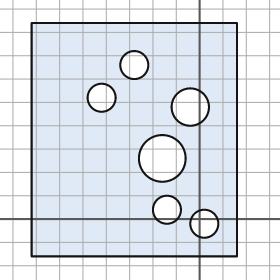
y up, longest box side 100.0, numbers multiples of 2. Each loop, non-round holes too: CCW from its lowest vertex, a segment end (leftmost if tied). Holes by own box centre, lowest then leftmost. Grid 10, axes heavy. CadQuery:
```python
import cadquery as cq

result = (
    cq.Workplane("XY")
    .moveTo(-72.0, -16.0)
    .lineTo(16.0, -16.0)
    .lineTo(16.0, 84.0)
    .lineTo(-72.0, 84.0)
    .close()
    .moveTo(2.0, -2.0)
    .circle(6.0)
    .moveTo(-14.0, 4.0)
    .circle(6.0)
    .moveTo(-16.0, 26.0)
    .circle(10.0)
    .moveTo(-4.0, 48.0)
    .circle(8.0)
    .moveTo(-42.0, 52.0)
    .circle(6.0)
    .moveTo(-28.0, 66.0)
    .circle(6.0)
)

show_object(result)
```